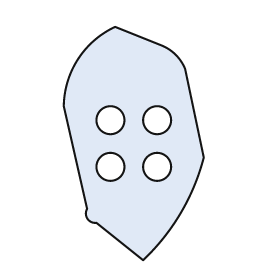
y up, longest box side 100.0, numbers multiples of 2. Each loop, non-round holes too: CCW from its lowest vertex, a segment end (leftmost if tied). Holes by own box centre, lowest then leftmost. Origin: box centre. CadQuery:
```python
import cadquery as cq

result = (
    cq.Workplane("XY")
    .moveTo(4.0, -50.0)
    .threePointArc((20.0, -30.0), (30.0, -6.0))
    .lineTo(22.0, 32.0)
    .threePointArc((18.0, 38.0), (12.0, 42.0))
    .lineTo(-8.0, 50.0)
    .threePointArc((-24.0, 36.0), (-30.0, 16.0))
    .lineTo(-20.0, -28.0)
    .threePointArc((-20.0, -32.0), (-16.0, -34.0))
    .close()
    .moveTo(-10.0, -10.0)
    .circle(6.0)
    .moveTo(10.0, -10.0)
    .circle(6.0)
    .moveTo(-10.0, 10.0)
    .circle(6.0)
    .moveTo(10.0, 10.0)
    .circle(6.0)
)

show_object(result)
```